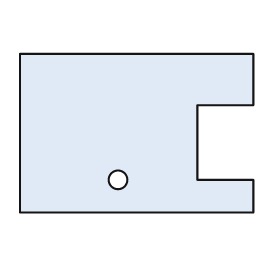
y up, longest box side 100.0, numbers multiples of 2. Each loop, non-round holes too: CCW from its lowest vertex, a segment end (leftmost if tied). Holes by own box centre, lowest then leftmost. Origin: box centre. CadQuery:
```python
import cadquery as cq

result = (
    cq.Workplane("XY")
    .moveTo(-50.0, -34.0)
    .lineTo(50.0, -34.0)
    .lineTo(50.0, -20.0)
    .lineTo(26.0, -20.0)
    .lineTo(26.0, 12.0)
    .lineTo(50.0, 12.0)
    .lineTo(50.0, 34.0)
    .lineTo(-50.0, 34.0)
    .close()
    .moveTo(-8.0, -20.0)
    .circle(4.0)
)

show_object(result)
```